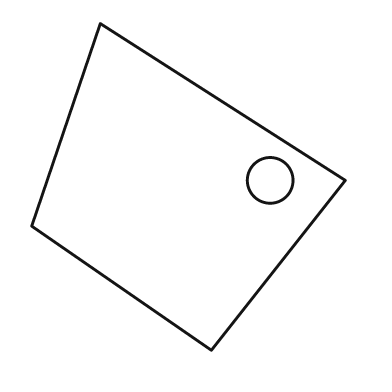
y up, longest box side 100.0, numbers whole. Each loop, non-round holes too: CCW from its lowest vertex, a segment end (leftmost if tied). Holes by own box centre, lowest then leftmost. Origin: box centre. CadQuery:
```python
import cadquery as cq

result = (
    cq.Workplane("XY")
    .moveTo(7.0, -50.0)
    .lineTo(48.0, 2.0)
    .lineTo(-27.0, 50.0)
    .lineTo(-48.0, -12.0)
    .close()
    .moveTo(25.0, 2.0)
    .circle(7.0)
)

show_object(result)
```